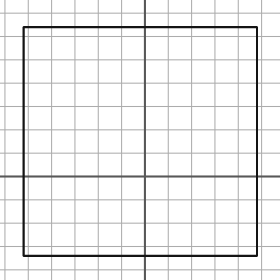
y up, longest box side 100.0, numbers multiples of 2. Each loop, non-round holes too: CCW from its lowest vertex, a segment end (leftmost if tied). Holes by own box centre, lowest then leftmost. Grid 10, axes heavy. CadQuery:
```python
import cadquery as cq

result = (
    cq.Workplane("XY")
    .moveTo(-52.0, -34.0)
    .lineTo(48.0, -34.0)
    .lineTo(48.0, 64.0)
    .lineTo(-52.0, 64.0)
    .close()
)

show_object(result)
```